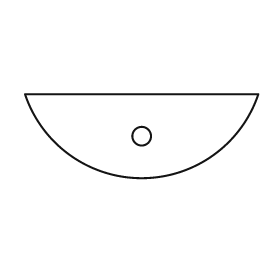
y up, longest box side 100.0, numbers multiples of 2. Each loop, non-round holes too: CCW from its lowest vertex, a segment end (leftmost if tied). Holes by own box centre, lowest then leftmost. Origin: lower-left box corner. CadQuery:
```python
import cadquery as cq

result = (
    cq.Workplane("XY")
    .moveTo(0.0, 36.0)
    .threePointArc((50.0, 0.0), (100.0, 36.0))
    .close()
    .moveTo(50.0, 18.0)
    .circle(4.0)
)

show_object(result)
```